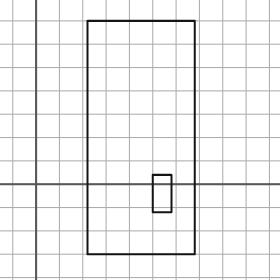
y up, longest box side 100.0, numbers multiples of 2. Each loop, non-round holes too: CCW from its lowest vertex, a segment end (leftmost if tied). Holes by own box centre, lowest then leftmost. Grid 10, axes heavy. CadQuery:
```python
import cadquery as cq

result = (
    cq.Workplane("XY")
    .moveTo(22.0, -30.0)
    .lineTo(68.0, -30.0)
    .lineTo(68.0, 70.0)
    .lineTo(22.0, 70.0)
    .close()
    .moveTo(50.0, -12.0)
    .lineTo(58.0, -12.0)
    .lineTo(58.0, 4.0)
    .lineTo(50.0, 4.0)
    .close()
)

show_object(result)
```